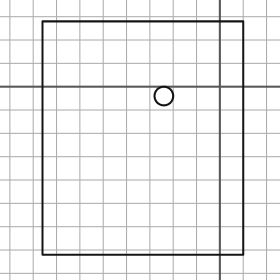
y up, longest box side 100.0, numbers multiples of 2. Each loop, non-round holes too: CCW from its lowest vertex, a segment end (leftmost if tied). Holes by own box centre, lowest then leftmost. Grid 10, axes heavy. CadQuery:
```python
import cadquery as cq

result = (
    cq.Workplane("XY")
    .moveTo(-76.0, -72.0)
    .lineTo(10.0, -72.0)
    .lineTo(10.0, 28.0)
    .lineTo(-76.0, 28.0)
    .close()
    .moveTo(-24.0, -4.0)
    .circle(4.0)
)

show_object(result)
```